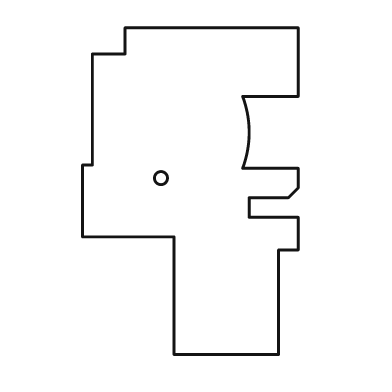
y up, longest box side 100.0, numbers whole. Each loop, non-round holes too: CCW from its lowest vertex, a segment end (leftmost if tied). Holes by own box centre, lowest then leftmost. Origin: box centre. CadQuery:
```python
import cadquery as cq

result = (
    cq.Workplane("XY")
    .moveTo(-5.0, -50.0)
    .lineTo(27.0, -50.0)
    .lineTo(27.0, -18.0)
    .lineTo(33.0, -18.0)
    .lineTo(33.0, -8.0)
    .lineTo(18.0, -8.0)
    .lineTo(18.0, -2.0)
    .lineTo(30.0, -2.0)
    .lineTo(33.0, 1.0)
    .lineTo(33.0, 7.0)
    .lineTo(16.0, 7.0)
    .threePointArc((18.0, 18.0), (16.0, 29.0))
    .lineTo(33.0, 29.0)
    .lineTo(33.0, 50.0)
    .lineTo(-20.0, 50.0)
    .lineTo(-20.0, 42.0)
    .lineTo(-30.0, 42.0)
    .lineTo(-30.0, 8.0)
    .lineTo(-33.0, 8.0)
    .lineTo(-33.0, -14.0)
    .lineTo(-5.0, -14.0)
    .close()
    .moveTo(-9.0, 4.0)
    .circle(2.0)
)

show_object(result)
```